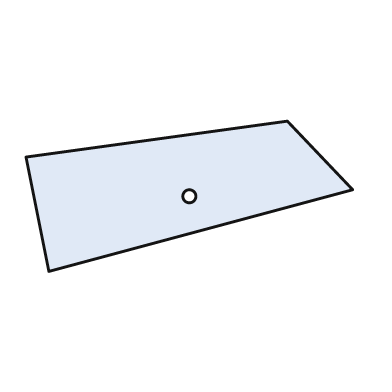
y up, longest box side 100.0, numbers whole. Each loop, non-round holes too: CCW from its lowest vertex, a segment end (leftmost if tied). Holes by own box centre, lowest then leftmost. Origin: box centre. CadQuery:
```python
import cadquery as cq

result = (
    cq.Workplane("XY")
    .moveTo(-43.0, -23.0)
    .lineTo(50.0, 2.0)
    .lineTo(30.0, 23.0)
    .lineTo(-50.0, 12.0)
    .close()
    .moveTo(0.0, 0.0)
    .circle(2.0)
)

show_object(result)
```